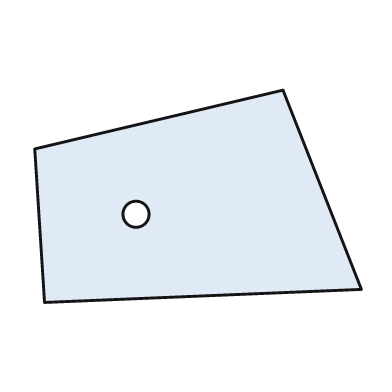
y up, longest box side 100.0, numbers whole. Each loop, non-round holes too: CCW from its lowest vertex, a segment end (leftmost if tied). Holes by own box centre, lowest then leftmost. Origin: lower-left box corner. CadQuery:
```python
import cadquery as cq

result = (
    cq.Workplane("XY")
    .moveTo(3.0, 0.0)
    .lineTo(100.0, 4.0)
    .lineTo(76.0, 65.0)
    .lineTo(0.0, 47.0)
    .close()
    .moveTo(31.0, 27.0)
    .circle(4.0)
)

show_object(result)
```